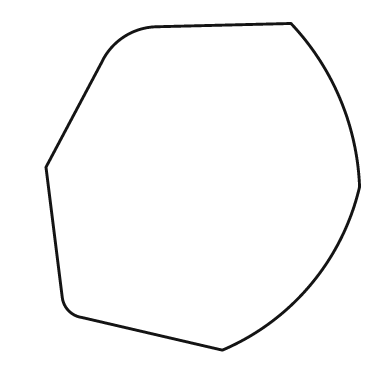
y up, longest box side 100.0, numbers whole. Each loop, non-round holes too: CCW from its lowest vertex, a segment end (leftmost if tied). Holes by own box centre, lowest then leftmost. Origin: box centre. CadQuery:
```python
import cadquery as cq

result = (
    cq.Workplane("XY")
    .moveTo(6.0, -50.0)
    .threePointArc((33.0, -30.0), (48.0, 0.0))
    .threePointArc((42.0, 27.0), (27.0, 50.0))
    .lineTo(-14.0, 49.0)
    .threePointArc((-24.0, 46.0), (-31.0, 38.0))
    .lineTo(-48.0, 6.0)
    .lineTo(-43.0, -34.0)
    .threePointArc((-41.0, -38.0), (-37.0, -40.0))
    .close()
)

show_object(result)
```